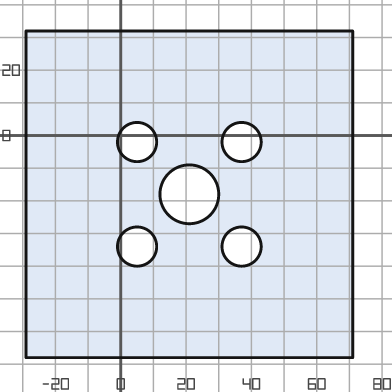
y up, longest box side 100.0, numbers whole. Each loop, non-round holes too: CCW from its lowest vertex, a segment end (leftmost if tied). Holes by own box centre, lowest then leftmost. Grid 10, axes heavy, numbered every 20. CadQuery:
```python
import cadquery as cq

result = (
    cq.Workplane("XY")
    .moveTo(-29.0, -68.0)
    .lineTo(71.0, -68.0)
    .lineTo(71.0, 32.0)
    .lineTo(-29.0, 32.0)
    .close()
    .moveTo(5.0, -34.0)
    .circle(6.0)
    .moveTo(37.0, -34.0)
    .circle(6.0)
    .moveTo(21.0, -18.0)
    .circle(9.0)
    .moveTo(5.0, -2.0)
    .circle(6.0)
    .moveTo(37.0, -2.0)
    .circle(6.0)
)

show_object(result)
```